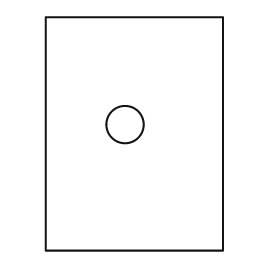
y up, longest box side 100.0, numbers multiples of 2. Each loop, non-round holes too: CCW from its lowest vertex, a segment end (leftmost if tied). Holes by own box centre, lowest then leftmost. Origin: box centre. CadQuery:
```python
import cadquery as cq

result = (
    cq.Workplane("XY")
    .moveTo(-38.0, -50.0)
    .lineTo(38.0, -50.0)
    .lineTo(38.0, 50.0)
    .lineTo(-38.0, 50.0)
    .close()
    .moveTo(-4.0, 4.0)
    .circle(8.0)
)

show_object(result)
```